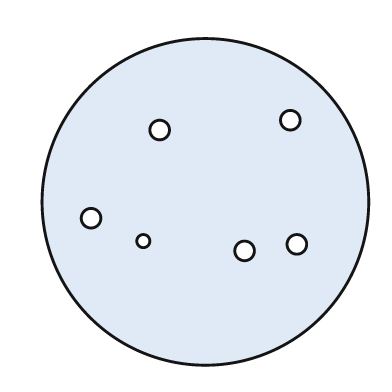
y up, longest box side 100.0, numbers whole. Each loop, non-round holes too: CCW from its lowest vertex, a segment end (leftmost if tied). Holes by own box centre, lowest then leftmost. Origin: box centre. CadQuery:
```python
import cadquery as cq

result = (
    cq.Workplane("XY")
    .moveTo(0.0, 0.0)
    .circle(50.0)
    .moveTo(12.0, -15.0)
    .circle(3.0)
    .moveTo(28.0, -13.0)
    .circle(3.0)
    .moveTo(-19.0, -12.0)
    .circle(2.0)
    .moveTo(-35.0, -5.0)
    .circle(3.0)
    .moveTo(-14.0, 22.0)
    .circle(3.0)
    .moveTo(26.0, 25.0)
    .circle(3.0)
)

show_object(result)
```